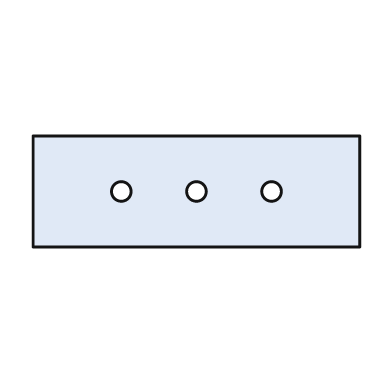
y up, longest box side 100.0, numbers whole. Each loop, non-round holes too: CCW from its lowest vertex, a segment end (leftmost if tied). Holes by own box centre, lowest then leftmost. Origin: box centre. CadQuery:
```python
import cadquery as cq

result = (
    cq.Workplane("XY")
    .moveTo(-50.0, -17.0)
    .lineTo(50.0, -17.0)
    .lineTo(50.0, 17.0)
    .lineTo(-50.0, 17.0)
    .close()
    .moveTo(-23.0, 0.0)
    .circle(3.0)
    .moveTo(0.0, 0.0)
    .circle(3.0)
    .moveTo(23.0, 0.0)
    .circle(3.0)
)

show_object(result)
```